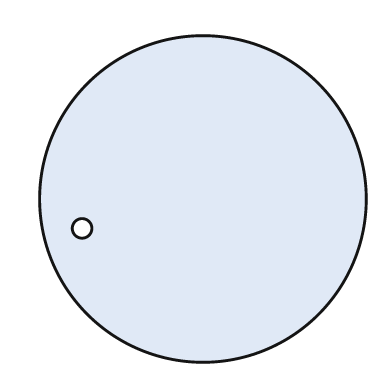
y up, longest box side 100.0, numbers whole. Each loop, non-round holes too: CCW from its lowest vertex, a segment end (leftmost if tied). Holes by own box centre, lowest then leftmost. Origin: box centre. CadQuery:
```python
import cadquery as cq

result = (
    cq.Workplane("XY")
    .moveTo(0.0, 0.0)
    .circle(50.0)
    .moveTo(-37.0, -9.0)
    .circle(3.0)
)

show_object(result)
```